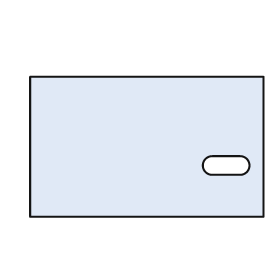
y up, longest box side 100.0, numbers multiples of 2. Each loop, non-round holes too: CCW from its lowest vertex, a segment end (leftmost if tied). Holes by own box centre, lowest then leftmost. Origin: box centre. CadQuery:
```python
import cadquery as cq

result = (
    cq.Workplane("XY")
    .moveTo(-50.0, -30.0)
    .lineTo(50.0, -30.0)
    .lineTo(50.0, 30.0)
    .lineTo(-50.0, 30.0)
    .close()
    .moveTo(28.0, -12.0)
    .lineTo(40.0, -12.0)
    .threePointArc((44.0, -8.0), (40.0, -4.0))
    .lineTo(28.0, -4.0)
    .threePointArc((24.0, -8.0), (28.0, -12.0))
    .close()
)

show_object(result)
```